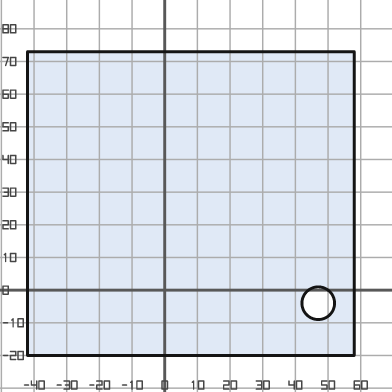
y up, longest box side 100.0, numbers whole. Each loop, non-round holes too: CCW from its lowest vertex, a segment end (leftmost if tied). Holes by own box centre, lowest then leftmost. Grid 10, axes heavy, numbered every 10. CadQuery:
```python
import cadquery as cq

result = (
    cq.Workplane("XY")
    .moveTo(-42.0, -20.0)
    .lineTo(58.0, -20.0)
    .lineTo(58.0, 73.0)
    .lineTo(-42.0, 73.0)
    .close()
    .moveTo(47.0, -4.0)
    .circle(5.0)
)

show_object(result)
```